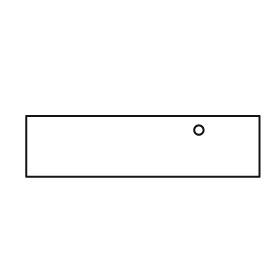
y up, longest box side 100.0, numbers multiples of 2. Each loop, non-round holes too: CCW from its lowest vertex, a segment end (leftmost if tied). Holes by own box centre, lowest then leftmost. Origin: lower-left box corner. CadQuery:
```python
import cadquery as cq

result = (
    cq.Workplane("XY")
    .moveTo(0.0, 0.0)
    .lineTo(100.0, 0.0)
    .lineTo(100.0, 26.0)
    .lineTo(0.0, 26.0)
    .close()
    .moveTo(74.0, 20.0)
    .circle(2.0)
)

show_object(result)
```